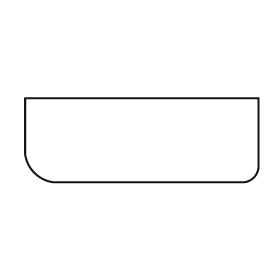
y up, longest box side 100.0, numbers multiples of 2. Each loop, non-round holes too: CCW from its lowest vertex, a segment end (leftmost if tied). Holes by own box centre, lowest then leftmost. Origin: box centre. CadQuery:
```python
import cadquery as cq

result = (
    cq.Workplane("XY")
    .moveTo(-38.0, -18.0)
    .lineTo(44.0, -18.0)
    .threePointArc((48.0, -16.0), (50.0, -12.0))
    .lineTo(50.0, 18.0)
    .lineTo(-50.0, 18.0)
    .lineTo(-50.0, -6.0)
    .threePointArc((-46.0, -14.0), (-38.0, -18.0))
    .close()
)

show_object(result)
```